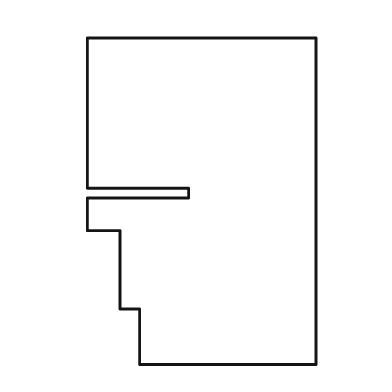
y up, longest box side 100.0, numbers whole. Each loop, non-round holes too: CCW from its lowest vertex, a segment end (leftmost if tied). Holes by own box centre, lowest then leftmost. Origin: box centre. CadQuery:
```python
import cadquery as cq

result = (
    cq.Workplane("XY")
    .moveTo(-19.0, -50.0)
    .lineTo(35.0, -50.0)
    .lineTo(35.0, 50.0)
    .lineTo(-35.0, 50.0)
    .lineTo(-35.0, 4.0)
    .lineTo(-4.0, 4.0)
    .lineTo(-4.0, 1.0)
    .lineTo(-35.0, 1.0)
    .lineTo(-35.0, -9.0)
    .lineTo(-25.0, -9.0)
    .lineTo(-25.0, -33.0)
    .lineTo(-19.0, -33.0)
    .close()
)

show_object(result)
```